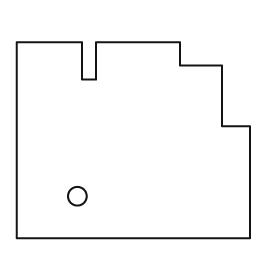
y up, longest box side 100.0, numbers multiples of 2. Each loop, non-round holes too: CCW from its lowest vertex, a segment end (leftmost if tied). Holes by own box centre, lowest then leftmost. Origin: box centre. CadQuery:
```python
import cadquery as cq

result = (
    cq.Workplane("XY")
    .moveTo(-50.0, -42.0)
    .lineTo(50.0, -42.0)
    .lineTo(50.0, 6.0)
    .lineTo(38.0, 6.0)
    .lineTo(38.0, 32.0)
    .lineTo(20.0, 32.0)
    .lineTo(20.0, 42.0)
    .lineTo(-16.0, 42.0)
    .lineTo(-16.0, 26.0)
    .lineTo(-22.0, 26.0)
    .lineTo(-22.0, 42.0)
    .lineTo(-50.0, 42.0)
    .close()
    .moveTo(-24.0, -24.0)
    .circle(4.0)
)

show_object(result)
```